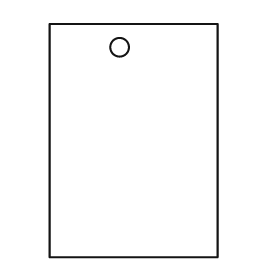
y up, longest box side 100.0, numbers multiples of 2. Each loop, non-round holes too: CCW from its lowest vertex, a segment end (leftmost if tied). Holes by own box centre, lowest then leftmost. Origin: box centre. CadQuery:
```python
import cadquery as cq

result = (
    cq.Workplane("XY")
    .moveTo(-36.0, -50.0)
    .lineTo(36.0, -50.0)
    .lineTo(36.0, 50.0)
    .lineTo(-36.0, 50.0)
    .close()
    .moveTo(-6.0, 40.0)
    .circle(4.0)
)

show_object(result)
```